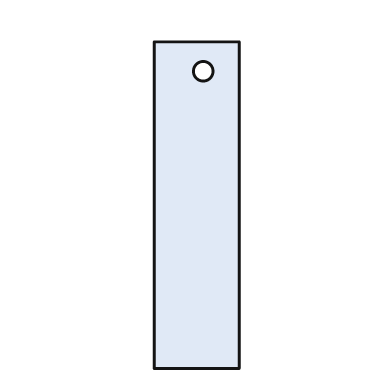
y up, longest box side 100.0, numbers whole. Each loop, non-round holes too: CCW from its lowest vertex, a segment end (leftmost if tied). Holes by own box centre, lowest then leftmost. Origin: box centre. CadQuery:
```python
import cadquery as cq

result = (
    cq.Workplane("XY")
    .moveTo(-13.0, -50.0)
    .lineTo(13.0, -50.0)
    .lineTo(13.0, 50.0)
    .lineTo(-13.0, 50.0)
    .close()
    .moveTo(2.0, 41.0)
    .circle(3.0)
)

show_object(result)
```